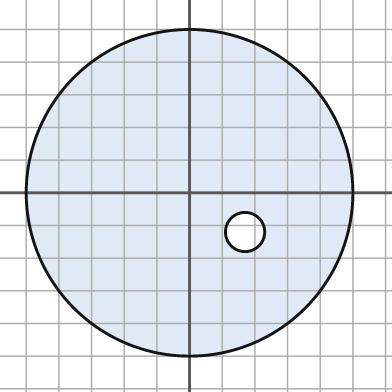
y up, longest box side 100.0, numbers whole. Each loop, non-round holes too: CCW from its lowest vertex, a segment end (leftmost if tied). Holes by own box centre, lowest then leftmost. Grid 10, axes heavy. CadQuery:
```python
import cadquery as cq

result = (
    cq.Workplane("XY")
    .moveTo(0.0, 0.0)
    .circle(50.0)
    .moveTo(17.0, -12.0)
    .circle(6.0)
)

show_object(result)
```